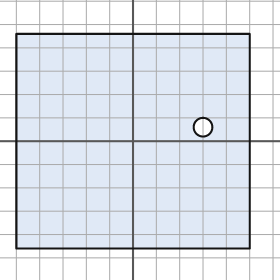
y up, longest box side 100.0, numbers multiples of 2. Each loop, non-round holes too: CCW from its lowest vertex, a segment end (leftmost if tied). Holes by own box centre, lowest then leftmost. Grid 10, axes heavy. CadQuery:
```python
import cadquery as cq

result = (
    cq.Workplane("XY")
    .moveTo(-50.0, -46.0)
    .lineTo(50.0, -46.0)
    .lineTo(50.0, 46.0)
    .lineTo(-50.0, 46.0)
    .close()
    .moveTo(30.0, 6.0)
    .circle(4.0)
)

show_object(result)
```